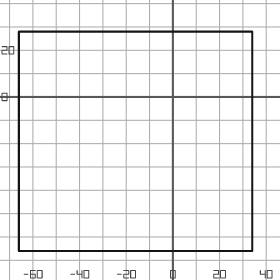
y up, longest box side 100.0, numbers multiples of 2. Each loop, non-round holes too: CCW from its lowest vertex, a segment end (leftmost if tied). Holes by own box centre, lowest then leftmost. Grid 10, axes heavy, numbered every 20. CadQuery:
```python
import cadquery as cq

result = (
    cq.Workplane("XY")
    .moveTo(-66.0, -66.0)
    .lineTo(34.0, -66.0)
    .lineTo(34.0, 28.0)
    .lineTo(-66.0, 28.0)
    .close()
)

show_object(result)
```